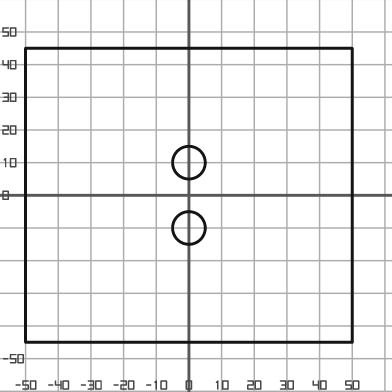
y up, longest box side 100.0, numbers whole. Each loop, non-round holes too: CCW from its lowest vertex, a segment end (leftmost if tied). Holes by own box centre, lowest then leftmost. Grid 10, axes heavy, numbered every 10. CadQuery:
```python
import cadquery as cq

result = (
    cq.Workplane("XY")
    .moveTo(-50.0, -45.0)
    .lineTo(50.0, -45.0)
    .lineTo(50.0, 45.0)
    .lineTo(-50.0, 45.0)
    .close()
    .moveTo(0.0, -10.0)
    .circle(5.0)
    .moveTo(0.0, 10.0)
    .circle(5.0)
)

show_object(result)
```